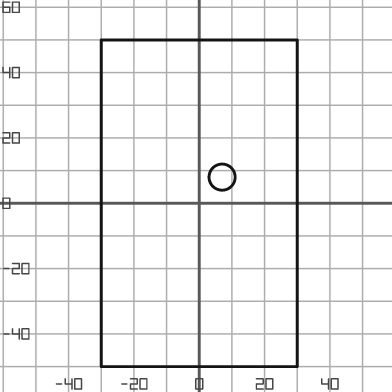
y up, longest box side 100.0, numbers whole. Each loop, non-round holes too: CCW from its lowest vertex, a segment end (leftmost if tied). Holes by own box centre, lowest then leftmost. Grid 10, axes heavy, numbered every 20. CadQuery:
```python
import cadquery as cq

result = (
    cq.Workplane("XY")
    .moveTo(-30.0, -50.0)
    .lineTo(30.0, -50.0)
    .lineTo(30.0, 50.0)
    .lineTo(-30.0, 50.0)
    .close()
    .moveTo(7.0, 8.0)
    .circle(4.0)
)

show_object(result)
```